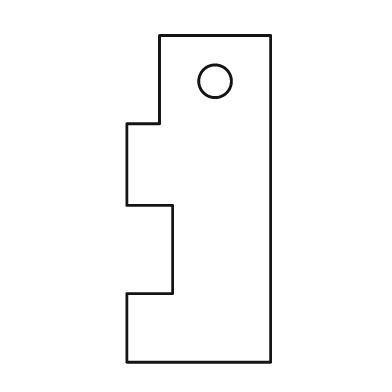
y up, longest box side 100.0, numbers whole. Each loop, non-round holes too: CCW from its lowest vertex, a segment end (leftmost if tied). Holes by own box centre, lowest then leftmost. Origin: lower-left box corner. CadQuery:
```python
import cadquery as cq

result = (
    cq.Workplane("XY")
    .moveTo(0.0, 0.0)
    .lineTo(44.0, 0.0)
    .lineTo(44.0, 100.0)
    .lineTo(10.0, 100.0)
    .lineTo(10.0, 73.0)
    .lineTo(0.0, 73.0)
    .lineTo(0.0, 48.0)
    .lineTo(14.0, 48.0)
    .lineTo(14.0, 21.0)
    .lineTo(0.0, 21.0)
    .close()
    .moveTo(27.0, 86.0)
    .circle(5.0)
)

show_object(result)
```